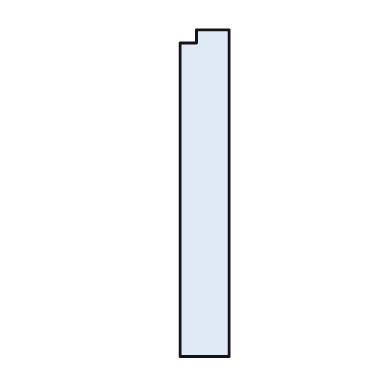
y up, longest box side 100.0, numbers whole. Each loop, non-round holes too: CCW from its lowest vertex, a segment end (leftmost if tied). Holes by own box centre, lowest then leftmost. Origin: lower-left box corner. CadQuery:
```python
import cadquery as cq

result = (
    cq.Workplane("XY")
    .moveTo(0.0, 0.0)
    .lineTo(15.0, 0.0)
    .lineTo(15.0, 100.0)
    .lineTo(5.0, 100.0)
    .lineTo(5.0, 96.0)
    .lineTo(0.0, 96.0)
    .close()
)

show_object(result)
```